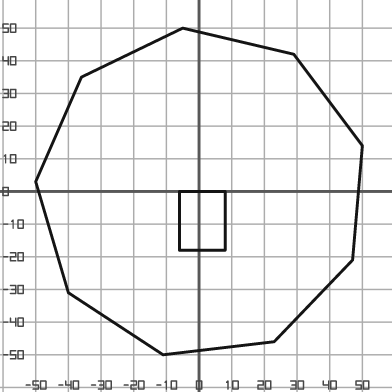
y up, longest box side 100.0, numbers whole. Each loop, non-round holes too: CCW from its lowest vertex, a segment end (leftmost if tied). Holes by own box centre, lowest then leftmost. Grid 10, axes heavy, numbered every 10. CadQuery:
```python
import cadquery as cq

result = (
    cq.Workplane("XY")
    .moveTo(-11.0, -50.0)
    .lineTo(23.0, -46.0)
    .lineTo(47.0, -21.0)
    .lineTo(50.0, 14.0)
    .lineTo(29.0, 42.0)
    .lineTo(-5.0, 50.0)
    .lineTo(-36.0, 35.0)
    .lineTo(-50.0, 3.0)
    .lineTo(-40.0, -31.0)
    .close()
    .moveTo(-6.0, -18.0)
    .lineTo(8.0, -18.0)
    .lineTo(8.0, 0.0)
    .lineTo(-6.0, 0.0)
    .close()
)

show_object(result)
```